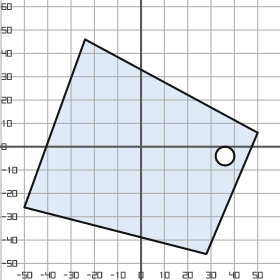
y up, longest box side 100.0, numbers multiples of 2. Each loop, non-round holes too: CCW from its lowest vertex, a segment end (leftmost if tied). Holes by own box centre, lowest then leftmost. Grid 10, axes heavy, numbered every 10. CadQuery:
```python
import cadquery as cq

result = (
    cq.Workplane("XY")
    .moveTo(28.0, -46.0)
    .lineTo(50.0, 6.0)
    .lineTo(-24.0, 46.0)
    .lineTo(-50.0, -26.0)
    .close()
    .moveTo(36.0, -4.0)
    .circle(4.0)
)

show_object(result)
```